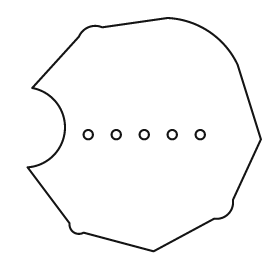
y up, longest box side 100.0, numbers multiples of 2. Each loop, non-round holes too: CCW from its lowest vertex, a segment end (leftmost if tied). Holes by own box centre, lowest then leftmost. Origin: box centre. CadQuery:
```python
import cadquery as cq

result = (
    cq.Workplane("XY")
    .moveTo(4.0, -50.0)
    .lineTo(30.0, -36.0)
    .threePointArc((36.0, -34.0), (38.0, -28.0))
    .lineTo(50.0, -2.0)
    .lineTo(40.0, 30.0)
    .threePointArc((28.0, 44.0), (10.0, 50.0))
    .lineTo(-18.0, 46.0)
    .threePointArc((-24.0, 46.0), (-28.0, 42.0))
    .lineTo(-48.0, 20.0)
    .threePointArc((-34.0, 2.0), (-50.0, -14.0))
    .lineTo(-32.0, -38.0)
    .threePointArc((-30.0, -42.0), (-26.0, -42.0))
    .close()
    .moveTo(-24.0, 0.0)
    .circle(2.0)
    .moveTo(-12.0, 0.0)
    .circle(2.0)
    .moveTo(0.0, 0.0)
    .circle(2.0)
    .moveTo(12.0, 0.0)
    .circle(2.0)
    .moveTo(24.0, 0.0)
    .circle(2.0)
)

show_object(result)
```